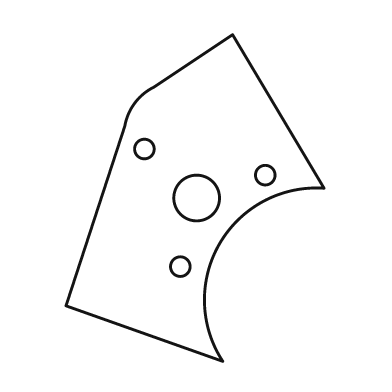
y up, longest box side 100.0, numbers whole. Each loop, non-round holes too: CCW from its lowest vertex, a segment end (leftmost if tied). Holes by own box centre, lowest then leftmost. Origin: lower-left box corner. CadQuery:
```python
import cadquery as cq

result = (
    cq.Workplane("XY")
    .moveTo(48.0, 0.0)
    .threePointArc((47.0, 36.0), (79.0, 53.0))
    .lineTo(51.0, 100.0)
    .lineTo(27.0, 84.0)
    .threePointArc((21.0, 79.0), (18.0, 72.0))
    .lineTo(0.0, 17.0)
    .close()
    .moveTo(35.0, 29.0)
    .circle(3.0)
    .moveTo(40.0, 50.0)
    .circle(7.0)
    .moveTo(61.0, 57.0)
    .circle(3.0)
    .moveTo(24.0, 65.0)
    .circle(3.0)
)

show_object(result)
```